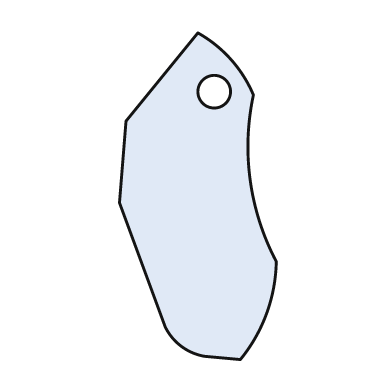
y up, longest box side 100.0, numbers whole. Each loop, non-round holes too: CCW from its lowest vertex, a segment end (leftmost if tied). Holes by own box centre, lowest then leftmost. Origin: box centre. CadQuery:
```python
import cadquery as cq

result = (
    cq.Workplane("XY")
    .moveTo(13.0, -50.0)
    .threePointArc((21.0, -36.0), (24.0, -20.0))
    .threePointArc((16.0, 5.0), (17.0, 31.0))
    .threePointArc((10.0, 42.0), (0.0, 50.0))
    .lineTo(-22.0, 23.0)
    .lineTo(-24.0, -2.0)
    .lineTo(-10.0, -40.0)
    .threePointArc((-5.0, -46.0), (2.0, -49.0))
    .close()
    .moveTo(5.0, 32.0)
    .circle(5.0)
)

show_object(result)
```